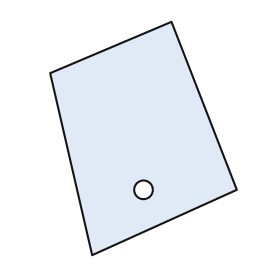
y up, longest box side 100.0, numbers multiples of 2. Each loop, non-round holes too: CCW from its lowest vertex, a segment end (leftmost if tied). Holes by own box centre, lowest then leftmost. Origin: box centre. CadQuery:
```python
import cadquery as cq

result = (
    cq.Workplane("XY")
    .moveTo(-22.0, -50.0)
    .lineTo(40.0, -22.0)
    .lineTo(12.0, 50.0)
    .lineTo(-40.0, 28.0)
    .close()
    .moveTo(0.0, -22.0)
    .circle(4.0)
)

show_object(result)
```